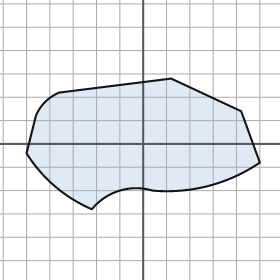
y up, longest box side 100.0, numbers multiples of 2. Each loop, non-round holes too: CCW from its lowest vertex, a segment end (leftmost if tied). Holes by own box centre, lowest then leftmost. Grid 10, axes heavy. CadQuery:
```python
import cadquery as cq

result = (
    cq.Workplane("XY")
    .moveTo(-22.0, -28.0)
    .threePointArc((-10.0, -20.0), (4.0, -20.0))
    .threePointArc((28.0, -18.0), (50.0, -8.0))
    .lineTo(42.0, 14.0)
    .lineTo(12.0, 28.0)
    .lineTo(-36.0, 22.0)
    .threePointArc((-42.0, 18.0), (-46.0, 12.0))
    .lineTo(-50.0, -4.0)
    .threePointArc((-38.0, -18.0), (-22.0, -28.0))
    .close()
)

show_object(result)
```